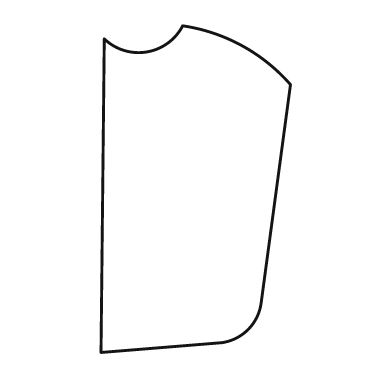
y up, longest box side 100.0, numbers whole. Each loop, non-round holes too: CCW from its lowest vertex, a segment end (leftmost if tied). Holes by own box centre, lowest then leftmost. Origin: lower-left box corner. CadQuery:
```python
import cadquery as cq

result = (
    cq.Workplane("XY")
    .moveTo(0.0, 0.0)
    .lineTo(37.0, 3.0)
    .threePointArc((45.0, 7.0), (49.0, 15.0))
    .lineTo(58.0, 82.0)
    .threePointArc((43.0, 94.0), (25.0, 100.0))
    .threePointArc((14.0, 92.0), (1.0, 96.0))
    .close()
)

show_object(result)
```